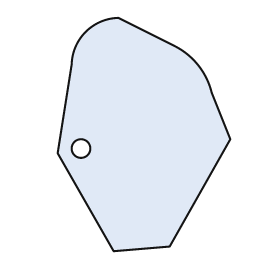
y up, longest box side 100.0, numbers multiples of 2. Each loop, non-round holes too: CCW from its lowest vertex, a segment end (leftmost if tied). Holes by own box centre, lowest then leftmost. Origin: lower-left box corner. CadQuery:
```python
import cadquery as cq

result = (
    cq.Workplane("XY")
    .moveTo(24.0, 0.0)
    .lineTo(48.0, 2.0)
    .lineTo(74.0, 48.0)
    .lineTo(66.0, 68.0)
    .threePointArc((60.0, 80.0), (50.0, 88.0))
    .lineTo(26.0, 100.0)
    .threePointArc((12.0, 94.0), (6.0, 80.0))
    .lineTo(0.0, 42.0)
    .close()
    .moveTo(10.0, 44.0)
    .circle(4.0)
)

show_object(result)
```